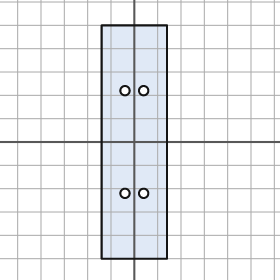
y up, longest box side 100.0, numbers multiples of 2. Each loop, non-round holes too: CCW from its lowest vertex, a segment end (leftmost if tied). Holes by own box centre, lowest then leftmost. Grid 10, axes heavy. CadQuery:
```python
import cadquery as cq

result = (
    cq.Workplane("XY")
    .moveTo(-14.0, -50.0)
    .lineTo(14.0, -50.0)
    .lineTo(14.0, 50.0)
    .lineTo(-14.0, 50.0)
    .close()
    .moveTo(-4.0, -22.0)
    .circle(2.0)
    .moveTo(4.0, -22.0)
    .circle(2.0)
    .moveTo(-4.0, 22.0)
    .circle(2.0)
    .moveTo(4.0, 22.0)
    .circle(2.0)
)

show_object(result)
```